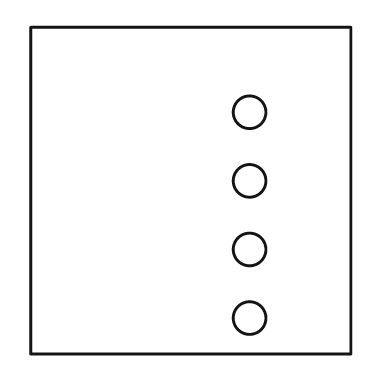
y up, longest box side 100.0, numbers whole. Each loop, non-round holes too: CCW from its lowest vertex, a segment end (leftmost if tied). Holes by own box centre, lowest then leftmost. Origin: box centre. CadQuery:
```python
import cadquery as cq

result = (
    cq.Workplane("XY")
    .moveTo(-49.0, -50.0)
    .lineTo(49.0, -50.0)
    .lineTo(49.0, 50.0)
    .lineTo(-49.0, 50.0)
    .close()
    .moveTo(18.0, -39.0)
    .circle(5.0)
    .moveTo(18.0, -18.0)
    .circle(5.0)
    .moveTo(18.0, 3.0)
    .circle(5.0)
    .moveTo(18.0, 24.0)
    .circle(5.0)
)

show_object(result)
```